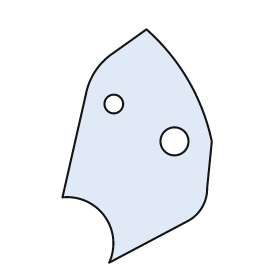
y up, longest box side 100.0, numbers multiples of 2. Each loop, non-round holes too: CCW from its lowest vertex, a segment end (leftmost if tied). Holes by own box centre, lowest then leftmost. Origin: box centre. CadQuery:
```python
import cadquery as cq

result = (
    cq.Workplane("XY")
    .moveTo(-12.0, -50.0)
    .lineTo(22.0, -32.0)
    .threePointArc((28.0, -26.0), (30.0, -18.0))
    .lineTo(32.0, 2.0)
    .threePointArc((22.0, 28.0), (4.0, 50.0))
    .lineTo(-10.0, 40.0)
    .threePointArc((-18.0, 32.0), (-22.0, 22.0))
    .lineTo(-32.0, -22.0)
    .threePointArc((-14.0, -30.0), (-12.0, -50.0))
    .close()
    .moveTo(16.0, 2.0)
    .circle(6.0)
    .moveTo(-10.0, 18.0)
    .circle(4.0)
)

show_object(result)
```